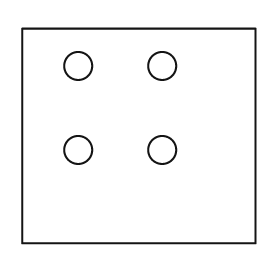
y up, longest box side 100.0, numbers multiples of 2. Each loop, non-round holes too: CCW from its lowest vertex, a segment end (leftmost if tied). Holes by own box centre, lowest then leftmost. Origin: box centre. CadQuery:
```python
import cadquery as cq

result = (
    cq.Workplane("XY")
    .moveTo(-50.0, -46.0)
    .lineTo(50.0, -46.0)
    .lineTo(50.0, 46.0)
    .lineTo(-50.0, 46.0)
    .close()
    .moveTo(-26.0, -6.0)
    .circle(6.0)
    .moveTo(10.0, -6.0)
    .circle(6.0)
    .moveTo(-26.0, 30.0)
    .circle(6.0)
    .moveTo(10.0, 30.0)
    .circle(6.0)
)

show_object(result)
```